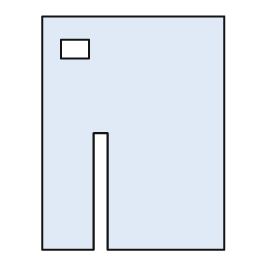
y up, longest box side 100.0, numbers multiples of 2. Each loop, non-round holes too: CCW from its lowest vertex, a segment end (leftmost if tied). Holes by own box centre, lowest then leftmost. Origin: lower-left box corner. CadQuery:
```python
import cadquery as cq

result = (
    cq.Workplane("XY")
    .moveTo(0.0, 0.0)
    .lineTo(22.0, 0.0)
    .lineTo(22.0, 50.0)
    .lineTo(28.0, 50.0)
    .lineTo(28.0, 0.0)
    .lineTo(78.0, 0.0)
    .lineTo(78.0, 100.0)
    .lineTo(0.0, 100.0)
    .close()
    .moveTo(8.0, 82.0)
    .lineTo(20.0, 82.0)
    .lineTo(20.0, 90.0)
    .lineTo(8.0, 90.0)
    .close()
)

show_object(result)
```